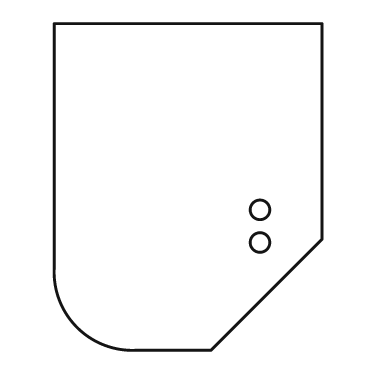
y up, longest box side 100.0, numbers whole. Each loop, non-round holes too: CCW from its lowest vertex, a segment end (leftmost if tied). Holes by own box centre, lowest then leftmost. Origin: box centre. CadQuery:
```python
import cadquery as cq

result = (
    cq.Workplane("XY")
    .moveTo(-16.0, -50.0)
    .lineTo(7.0, -50.0)
    .lineTo(41.0, -16.0)
    .lineTo(41.0, 50.0)
    .lineTo(-41.0, 50.0)
    .lineTo(-41.0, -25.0)
    .threePointArc((-34.0, -43.0), (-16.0, -50.0))
    .close()
    .moveTo(22.0, -17.0)
    .circle(3.0)
    .moveTo(22.0, -7.0)
    .circle(3.0)
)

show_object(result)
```